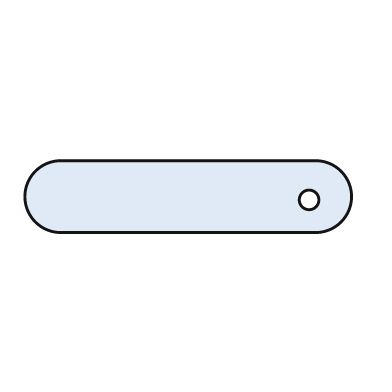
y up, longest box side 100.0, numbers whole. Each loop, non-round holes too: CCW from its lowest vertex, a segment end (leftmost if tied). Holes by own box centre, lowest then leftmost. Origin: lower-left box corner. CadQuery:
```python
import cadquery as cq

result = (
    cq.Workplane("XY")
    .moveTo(11.0, 0.0)
    .lineTo(89.0, 0.0)
    .threePointArc((100.0, 11.0), (89.0, 22.0))
    .lineTo(11.0, 22.0)
    .threePointArc((0.0, 11.0), (11.0, 0.0))
    .close()
    .moveTo(87.0, 10.0)
    .circle(3.0)
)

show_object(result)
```